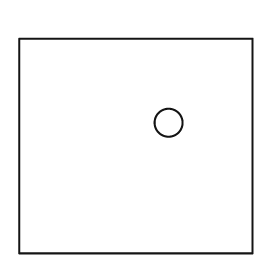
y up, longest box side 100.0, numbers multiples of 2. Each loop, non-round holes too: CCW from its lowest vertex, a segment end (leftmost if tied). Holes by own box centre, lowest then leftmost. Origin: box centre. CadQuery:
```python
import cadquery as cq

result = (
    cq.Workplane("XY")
    .moveTo(-50.0, -46.0)
    .lineTo(50.0, -46.0)
    .lineTo(50.0, 46.0)
    .lineTo(-50.0, 46.0)
    .close()
    .moveTo(14.0, 10.0)
    .circle(6.0)
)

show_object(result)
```